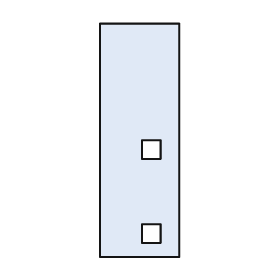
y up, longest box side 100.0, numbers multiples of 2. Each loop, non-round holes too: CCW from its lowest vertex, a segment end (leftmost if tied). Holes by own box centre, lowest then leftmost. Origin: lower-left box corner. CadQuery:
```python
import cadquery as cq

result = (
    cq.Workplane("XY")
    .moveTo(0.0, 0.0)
    .lineTo(34.0, 0.0)
    .lineTo(34.0, 100.0)
    .lineTo(0.0, 100.0)
    .close()
    .moveTo(18.0, 6.0)
    .lineTo(26.0, 6.0)
    .lineTo(26.0, 14.0)
    .lineTo(18.0, 14.0)
    .close()
    .moveTo(18.0, 42.0)
    .lineTo(26.0, 42.0)
    .lineTo(26.0, 50.0)
    .lineTo(18.0, 50.0)
    .close()
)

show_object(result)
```